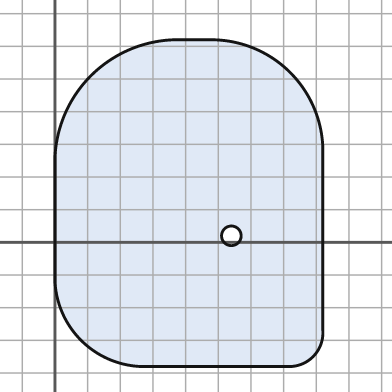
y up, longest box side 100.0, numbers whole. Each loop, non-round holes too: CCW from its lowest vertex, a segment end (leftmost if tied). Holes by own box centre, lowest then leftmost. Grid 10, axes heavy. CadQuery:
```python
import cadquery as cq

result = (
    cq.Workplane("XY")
    .moveTo(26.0, -38.0)
    .lineTo(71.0, -38.0)
    .threePointArc((79.0, -35.0), (82.0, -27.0))
    .lineTo(82.0, 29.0)
    .threePointArc((72.0, 52.0), (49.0, 62.0))
    .lineTo(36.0, 62.0)
    .threePointArc((11.0, 51.0), (0.0, 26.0))
    .lineTo(0.0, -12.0)
    .threePointArc((8.0, -30.0), (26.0, -38.0))
    .close()
    .moveTo(54.0, 2.0)
    .circle(3.0)
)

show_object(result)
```